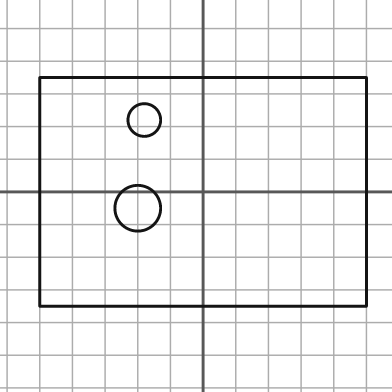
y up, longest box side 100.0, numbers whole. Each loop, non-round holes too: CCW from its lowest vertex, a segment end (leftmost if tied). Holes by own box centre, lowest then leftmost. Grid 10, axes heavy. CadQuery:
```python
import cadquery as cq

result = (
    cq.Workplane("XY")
    .moveTo(-50.0, -35.0)
    .lineTo(50.0, -35.0)
    .lineTo(50.0, 35.0)
    .lineTo(-50.0, 35.0)
    .close()
    .moveTo(-20.0, -5.0)
    .circle(7.0)
    .moveTo(-18.0, 22.0)
    .circle(5.0)
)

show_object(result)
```